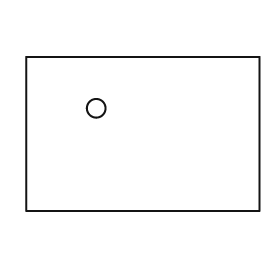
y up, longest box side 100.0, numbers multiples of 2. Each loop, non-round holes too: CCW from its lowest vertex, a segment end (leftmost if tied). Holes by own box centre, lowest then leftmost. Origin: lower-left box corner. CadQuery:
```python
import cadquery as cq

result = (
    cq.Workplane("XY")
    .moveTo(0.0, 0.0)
    .lineTo(100.0, 0.0)
    .lineTo(100.0, 66.0)
    .lineTo(0.0, 66.0)
    .close()
    .moveTo(30.0, 44.0)
    .circle(4.0)
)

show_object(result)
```